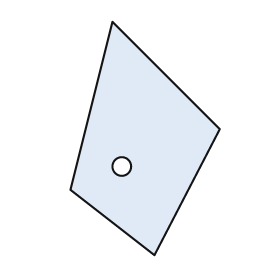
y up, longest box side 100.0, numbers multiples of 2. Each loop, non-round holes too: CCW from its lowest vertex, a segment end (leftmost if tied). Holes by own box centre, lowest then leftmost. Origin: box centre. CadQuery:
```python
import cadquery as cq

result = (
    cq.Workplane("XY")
    .moveTo(4.0, -50.0)
    .lineTo(32.0, 4.0)
    .lineTo(-14.0, 50.0)
    .lineTo(-32.0, -22.0)
    .close()
    .moveTo(-10.0, -12.0)
    .circle(4.0)
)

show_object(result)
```